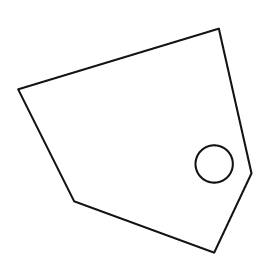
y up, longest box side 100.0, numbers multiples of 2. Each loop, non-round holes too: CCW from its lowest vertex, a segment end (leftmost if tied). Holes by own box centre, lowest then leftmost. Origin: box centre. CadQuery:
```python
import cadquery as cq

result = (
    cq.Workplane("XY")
    .moveTo(34.0, -48.0)
    .lineTo(50.0, -14.0)
    .lineTo(36.0, 48.0)
    .lineTo(-50.0, 22.0)
    .lineTo(-26.0, -26.0)
    .close()
    .moveTo(34.0, -10.0)
    .circle(8.0)
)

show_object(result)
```